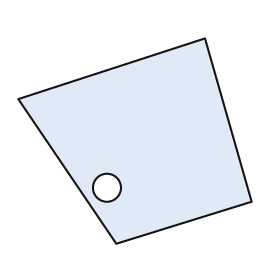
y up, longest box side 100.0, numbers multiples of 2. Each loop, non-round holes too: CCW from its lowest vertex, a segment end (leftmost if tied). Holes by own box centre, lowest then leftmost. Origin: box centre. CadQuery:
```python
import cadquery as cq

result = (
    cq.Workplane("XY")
    .moveTo(-8.0, -44.0)
    .lineTo(50.0, -26.0)
    .lineTo(30.0, 44.0)
    .lineTo(-50.0, 18.0)
    .close()
    .moveTo(-12.0, -20.0)
    .circle(6.0)
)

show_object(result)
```